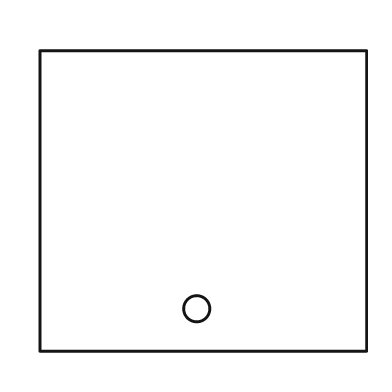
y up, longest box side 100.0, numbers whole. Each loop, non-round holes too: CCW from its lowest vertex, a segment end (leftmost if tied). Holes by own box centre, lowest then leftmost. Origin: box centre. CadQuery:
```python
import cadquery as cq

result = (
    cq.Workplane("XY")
    .moveTo(-50.0, -46.0)
    .lineTo(50.0, -46.0)
    .lineTo(50.0, 46.0)
    .lineTo(-50.0, 46.0)
    .close()
    .moveTo(-2.0, -33.0)
    .circle(4.0)
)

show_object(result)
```